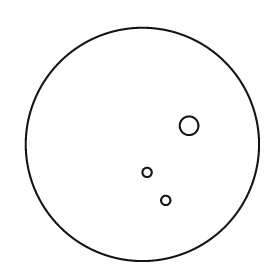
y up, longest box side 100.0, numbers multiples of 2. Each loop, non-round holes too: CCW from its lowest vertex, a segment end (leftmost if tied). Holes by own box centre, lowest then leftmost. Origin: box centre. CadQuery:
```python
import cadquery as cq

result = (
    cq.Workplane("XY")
    .moveTo(0.0, 0.0)
    .circle(50.0)
    .moveTo(10.0, -24.0)
    .circle(2.0)
    .moveTo(2.0, -12.0)
    .circle(2.0)
    .moveTo(20.0, 8.0)
    .circle(4.0)
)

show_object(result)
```